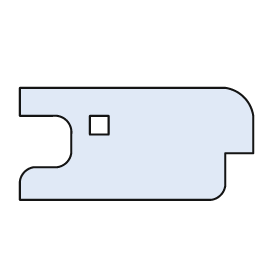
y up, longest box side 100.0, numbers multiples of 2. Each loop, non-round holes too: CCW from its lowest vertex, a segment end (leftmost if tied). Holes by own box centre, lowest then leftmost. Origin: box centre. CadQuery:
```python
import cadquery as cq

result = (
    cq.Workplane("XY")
    .moveTo(-50.0, -24.0)
    .lineTo(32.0, -24.0)
    .threePointArc((36.0, -22.0), (38.0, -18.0))
    .lineTo(38.0, -4.0)
    .lineTo(50.0, -4.0)
    .lineTo(50.0, 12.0)
    .threePointArc((46.0, 20.0), (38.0, 24.0))
    .lineTo(-50.0, 24.0)
    .lineTo(-50.0, 12.0)
    .lineTo(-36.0, 12.0)
    .threePointArc((-30.0, 10.0), (-28.0, 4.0))
    .lineTo(-28.0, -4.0)
    .threePointArc((-30.0, -8.0), (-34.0, -10.0))
    .lineTo(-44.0, -10.0)
    .threePointArc((-48.0, -12.0), (-50.0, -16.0))
    .close()
    .moveTo(-20.0, 4.0)
    .lineTo(-12.0, 4.0)
    .lineTo(-12.0, 12.0)
    .lineTo(-20.0, 12.0)
    .close()
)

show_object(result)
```